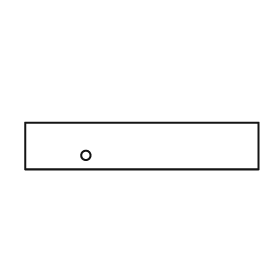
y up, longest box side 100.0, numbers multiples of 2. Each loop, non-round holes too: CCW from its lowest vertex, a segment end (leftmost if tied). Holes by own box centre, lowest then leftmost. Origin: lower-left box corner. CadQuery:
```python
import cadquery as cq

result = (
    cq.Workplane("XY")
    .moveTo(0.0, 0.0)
    .lineTo(100.0, 0.0)
    .lineTo(100.0, 20.0)
    .lineTo(0.0, 20.0)
    .close()
    .moveTo(26.0, 6.0)
    .circle(2.0)
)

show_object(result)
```